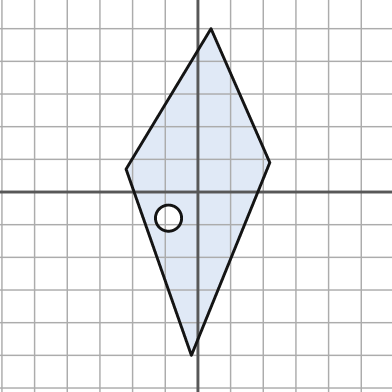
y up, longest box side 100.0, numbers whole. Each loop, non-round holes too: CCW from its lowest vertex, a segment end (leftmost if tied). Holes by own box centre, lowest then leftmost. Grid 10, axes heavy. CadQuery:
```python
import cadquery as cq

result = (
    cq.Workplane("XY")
    .moveTo(-2.0, -50.0)
    .lineTo(22.0, 9.0)
    .lineTo(4.0, 50.0)
    .lineTo(-22.0, 7.0)
    .close()
    .moveTo(-9.0, -8.0)
    .circle(4.0)
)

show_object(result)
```